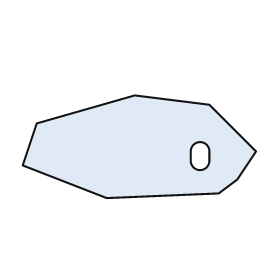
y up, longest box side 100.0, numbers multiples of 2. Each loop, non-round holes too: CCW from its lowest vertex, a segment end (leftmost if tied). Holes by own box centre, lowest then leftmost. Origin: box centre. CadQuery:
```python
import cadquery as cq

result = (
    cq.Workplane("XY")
    .moveTo(-14.0, -22.0)
    .lineTo(34.0, -20.0)
    .lineTo(42.0, -14.0)
    .lineTo(50.0, -2.0)
    .lineTo(30.0, 18.0)
    .lineTo(-2.0, 22.0)
    .lineTo(-44.0, 10.0)
    .lineTo(-50.0, -8.0)
    .close()
    .moveTo(22.0, -6.0)
    .threePointArc((26.0, -10.0), (30.0, -6.0))
    .lineTo(30.0, -2.0)
    .threePointArc((26.0, 2.0), (22.0, -2.0))
    .close()
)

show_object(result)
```